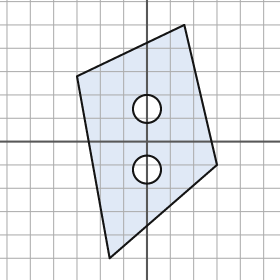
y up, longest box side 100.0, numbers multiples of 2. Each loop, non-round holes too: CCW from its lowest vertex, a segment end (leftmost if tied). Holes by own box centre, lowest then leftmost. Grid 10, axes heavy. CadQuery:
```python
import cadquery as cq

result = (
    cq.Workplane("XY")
    .moveTo(-16.0, -50.0)
    .lineTo(30.0, -10.0)
    .lineTo(16.0, 50.0)
    .lineTo(-30.0, 28.0)
    .close()
    .moveTo(0.0, -12.0)
    .circle(6.0)
    .moveTo(0.0, 14.0)
    .circle(6.0)
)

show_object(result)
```